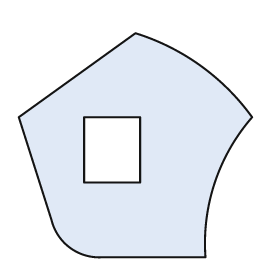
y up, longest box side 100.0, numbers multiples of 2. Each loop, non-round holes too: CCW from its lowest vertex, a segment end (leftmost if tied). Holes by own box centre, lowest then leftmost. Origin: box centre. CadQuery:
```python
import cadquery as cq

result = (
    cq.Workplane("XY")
    .moveTo(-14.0, -48.0)
    .lineTo(30.0, -48.0)
    .threePointArc((34.0, -16.0), (50.0, 12.0))
    .threePointArc((28.0, 34.0), (0.0, 48.0))
    .lineTo(-50.0, 12.0)
    .lineTo(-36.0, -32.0)
    .threePointArc((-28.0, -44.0), (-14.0, -48.0))
    .close()
    .moveTo(-22.0, -16.0)
    .lineTo(2.0, -16.0)
    .lineTo(2.0, 12.0)
    .lineTo(-22.0, 12.0)
    .close()
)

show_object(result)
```